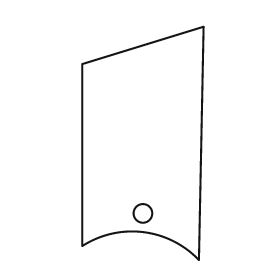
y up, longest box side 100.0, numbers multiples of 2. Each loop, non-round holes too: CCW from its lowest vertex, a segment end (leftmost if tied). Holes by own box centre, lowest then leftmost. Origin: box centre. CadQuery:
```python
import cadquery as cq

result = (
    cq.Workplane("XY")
    .moveTo(24.0, -50.0)
    .lineTo(26.0, 50.0)
    .lineTo(-26.0, 34.0)
    .lineTo(-26.0, -44.0)
    .threePointArc((0.0, -38.0), (24.0, -50.0))
    .close()
    .moveTo(0.0, -30.0)
    .circle(4.0)
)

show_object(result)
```